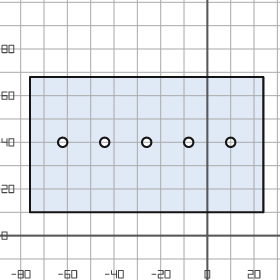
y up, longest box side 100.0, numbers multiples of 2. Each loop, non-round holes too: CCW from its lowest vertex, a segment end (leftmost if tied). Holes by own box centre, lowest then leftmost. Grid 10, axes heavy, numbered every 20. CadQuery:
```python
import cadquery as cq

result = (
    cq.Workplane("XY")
    .moveTo(-76.0, 10.0)
    .lineTo(24.0, 10.0)
    .lineTo(24.0, 68.0)
    .lineTo(-76.0, 68.0)
    .close()
    .moveTo(-62.0, 40.0)
    .circle(2.0)
    .moveTo(-44.0, 40.0)
    .circle(2.0)
    .moveTo(-26.0, 40.0)
    .circle(2.0)
    .moveTo(-8.0, 40.0)
    .circle(2.0)
    .moveTo(10.0, 40.0)
    .circle(2.0)
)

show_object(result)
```